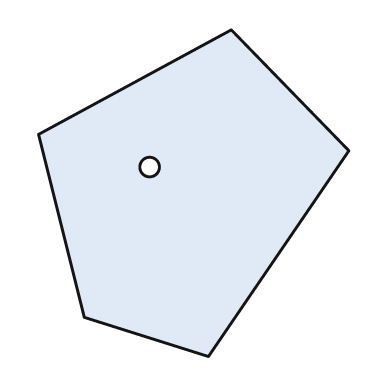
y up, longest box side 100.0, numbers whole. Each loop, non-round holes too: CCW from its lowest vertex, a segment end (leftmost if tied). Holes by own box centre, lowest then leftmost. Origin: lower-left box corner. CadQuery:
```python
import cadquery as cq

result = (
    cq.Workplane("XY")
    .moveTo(52.0, 0.0)
    .lineTo(95.0, 63.0)
    .lineTo(59.0, 100.0)
    .lineTo(0.0, 68.0)
    .lineTo(14.0, 12.0)
    .close()
    .moveTo(34.0, 58.0)
    .circle(3.0)
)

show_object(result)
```